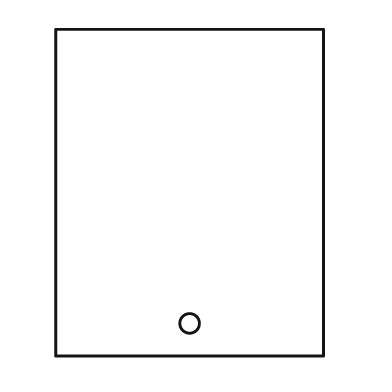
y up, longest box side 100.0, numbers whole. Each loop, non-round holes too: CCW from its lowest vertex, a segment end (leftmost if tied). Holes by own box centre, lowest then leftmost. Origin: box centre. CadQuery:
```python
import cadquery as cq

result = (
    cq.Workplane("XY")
    .moveTo(-41.0, -50.0)
    .lineTo(41.0, -50.0)
    .lineTo(41.0, 50.0)
    .lineTo(-41.0, 50.0)
    .close()
    .moveTo(0.0, -40.0)
    .circle(3.0)
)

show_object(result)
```